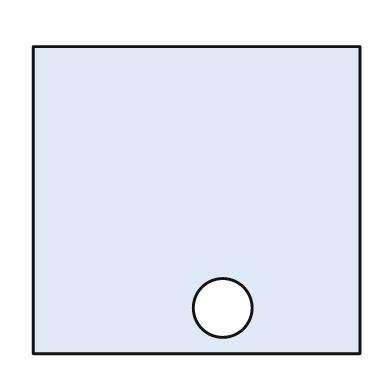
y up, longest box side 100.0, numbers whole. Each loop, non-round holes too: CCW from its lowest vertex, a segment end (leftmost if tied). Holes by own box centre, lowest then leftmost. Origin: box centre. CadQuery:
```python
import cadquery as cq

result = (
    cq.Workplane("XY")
    .moveTo(-50.0, -47.0)
    .lineTo(50.0, -47.0)
    .lineTo(50.0, 47.0)
    .lineTo(-50.0, 47.0)
    .close()
    .moveTo(8.0, -33.0)
    .circle(9.0)
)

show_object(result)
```